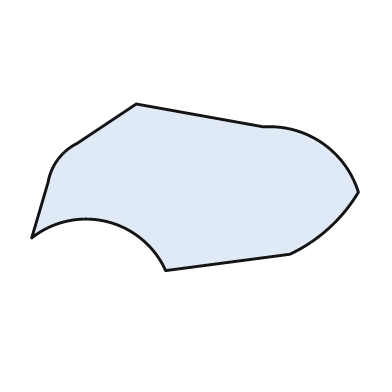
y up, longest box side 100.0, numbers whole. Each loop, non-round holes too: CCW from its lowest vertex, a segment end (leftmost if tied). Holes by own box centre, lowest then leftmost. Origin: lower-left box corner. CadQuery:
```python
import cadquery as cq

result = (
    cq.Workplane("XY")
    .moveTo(41.0, 0.0)
    .lineTo(79.0, 5.0)
    .threePointArc((91.0, 13.0), (100.0, 24.0))
    .threePointArc((89.0, 39.0), (71.0, 44.0))
    .lineTo(32.0, 51.0)
    .lineTo(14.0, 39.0)
    .threePointArc((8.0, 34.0), (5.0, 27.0))
    .lineTo(0.0, 10.0)
    .threePointArc((23.0, 15.0), (41.0, 0.0))
    .close()
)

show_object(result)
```